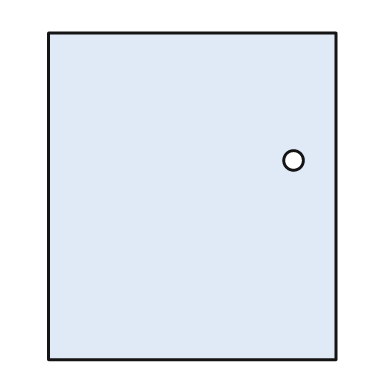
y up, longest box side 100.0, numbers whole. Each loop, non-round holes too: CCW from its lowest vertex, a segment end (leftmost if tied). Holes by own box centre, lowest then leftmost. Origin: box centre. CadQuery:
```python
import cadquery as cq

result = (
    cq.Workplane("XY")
    .moveTo(-44.0, -50.0)
    .lineTo(44.0, -50.0)
    .lineTo(44.0, 50.0)
    .lineTo(-44.0, 50.0)
    .close()
    .moveTo(31.0, 11.0)
    .circle(3.0)
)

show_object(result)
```